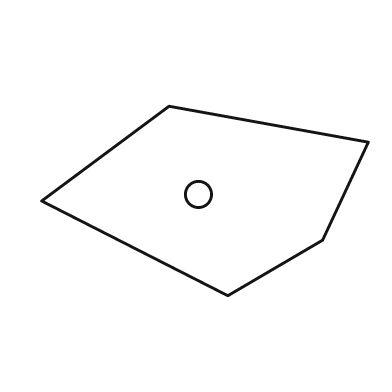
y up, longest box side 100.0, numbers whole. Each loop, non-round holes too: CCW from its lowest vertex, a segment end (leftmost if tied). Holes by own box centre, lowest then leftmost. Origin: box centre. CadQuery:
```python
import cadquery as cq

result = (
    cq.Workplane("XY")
    .moveTo(7.0, -29.0)
    .lineTo(36.0, -12.0)
    .lineTo(50.0, 18.0)
    .lineTo(-11.0, 29.0)
    .lineTo(-50.0, 0.0)
    .close()
    .moveTo(-2.0, 2.0)
    .circle(4.0)
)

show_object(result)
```